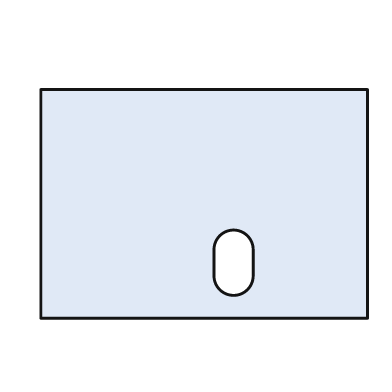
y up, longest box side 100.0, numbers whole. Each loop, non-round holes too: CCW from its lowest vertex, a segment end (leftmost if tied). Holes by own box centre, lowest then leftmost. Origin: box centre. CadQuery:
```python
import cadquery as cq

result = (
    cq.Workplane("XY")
    .moveTo(-50.0, -35.0)
    .lineTo(50.0, -35.0)
    .lineTo(50.0, 35.0)
    .lineTo(-50.0, 35.0)
    .close()
    .moveTo(3.0, -22.0)
    .threePointArc((9.0, -28.0), (15.0, -22.0))
    .lineTo(15.0, -14.0)
    .threePointArc((9.0, -8.0), (3.0, -14.0))
    .close()
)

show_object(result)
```